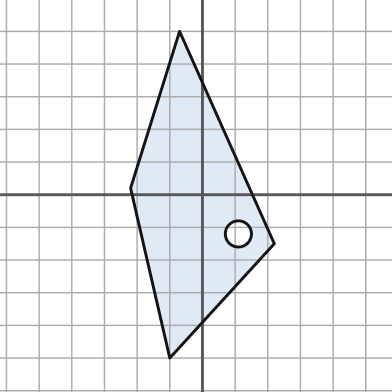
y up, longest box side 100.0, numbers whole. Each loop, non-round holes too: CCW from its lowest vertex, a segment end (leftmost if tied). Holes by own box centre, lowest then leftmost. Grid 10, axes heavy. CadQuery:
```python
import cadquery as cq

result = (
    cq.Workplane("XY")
    .moveTo(-10.0, -50.0)
    .lineTo(22.0, -15.0)
    .lineTo(-7.0, 50.0)
    .lineTo(-22.0, 2.0)
    .close()
    .moveTo(11.0, -12.0)
    .circle(4.0)
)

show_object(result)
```